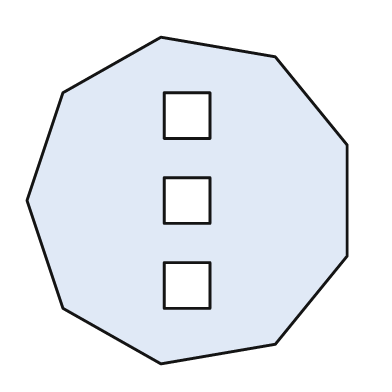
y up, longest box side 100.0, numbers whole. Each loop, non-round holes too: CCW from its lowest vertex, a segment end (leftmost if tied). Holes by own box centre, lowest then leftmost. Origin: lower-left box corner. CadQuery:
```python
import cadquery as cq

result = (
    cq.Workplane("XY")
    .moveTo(41.0, 0.0)
    .lineTo(76.0, 6.0)
    .lineTo(98.0, 33.0)
    .lineTo(98.0, 67.0)
    .lineTo(76.0, 94.0)
    .lineTo(41.0, 100.0)
    .lineTo(11.0, 83.0)
    .lineTo(0.0, 50.0)
    .lineTo(11.0, 17.0)
    .close()
    .moveTo(42.0, 17.0)
    .lineTo(56.0, 17.0)
    .lineTo(56.0, 31.0)
    .lineTo(42.0, 31.0)
    .close()
    .moveTo(42.0, 43.0)
    .lineTo(56.0, 43.0)
    .lineTo(56.0, 57.0)
    .lineTo(42.0, 57.0)
    .close()
    .moveTo(42.0, 69.0)
    .lineTo(56.0, 69.0)
    .lineTo(56.0, 83.0)
    .lineTo(42.0, 83.0)
    .close()
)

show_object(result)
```